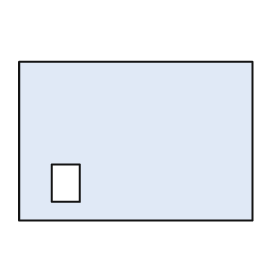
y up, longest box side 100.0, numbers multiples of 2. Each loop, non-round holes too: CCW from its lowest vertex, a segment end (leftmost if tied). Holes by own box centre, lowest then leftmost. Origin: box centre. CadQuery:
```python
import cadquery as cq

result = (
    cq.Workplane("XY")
    .moveTo(-50.0, -34.0)
    .lineTo(50.0, -34.0)
    .lineTo(50.0, 34.0)
    .lineTo(-50.0, 34.0)
    .close()
    .moveTo(-36.0, -26.0)
    .lineTo(-24.0, -26.0)
    .lineTo(-24.0, -10.0)
    .lineTo(-36.0, -10.0)
    .close()
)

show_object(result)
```